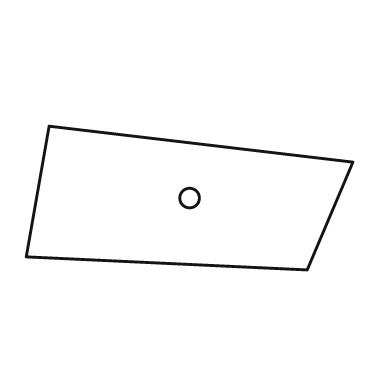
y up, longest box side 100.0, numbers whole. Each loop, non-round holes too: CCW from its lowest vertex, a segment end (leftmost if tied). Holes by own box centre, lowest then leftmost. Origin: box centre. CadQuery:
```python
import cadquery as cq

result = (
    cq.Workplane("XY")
    .moveTo(36.0, -22.0)
    .lineTo(50.0, 11.0)
    .lineTo(-43.0, 22.0)
    .lineTo(-50.0, -18.0)
    .close()
    .moveTo(0.0, 0.0)
    .circle(3.0)
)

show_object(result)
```